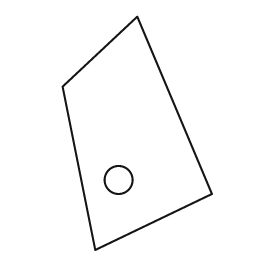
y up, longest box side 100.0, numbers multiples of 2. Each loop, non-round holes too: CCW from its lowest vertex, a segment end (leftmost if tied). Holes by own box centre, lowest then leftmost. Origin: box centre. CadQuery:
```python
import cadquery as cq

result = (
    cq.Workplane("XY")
    .moveTo(-18.0, -50.0)
    .lineTo(32.0, -26.0)
    .lineTo(0.0, 50.0)
    .lineTo(-32.0, 20.0)
    .close()
    .moveTo(-8.0, -20.0)
    .circle(6.0)
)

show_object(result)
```